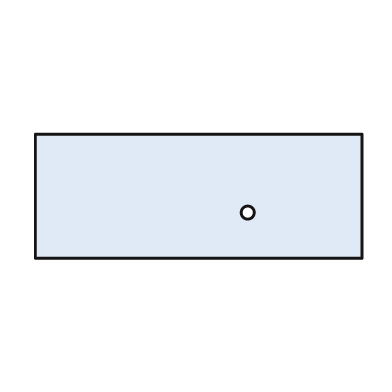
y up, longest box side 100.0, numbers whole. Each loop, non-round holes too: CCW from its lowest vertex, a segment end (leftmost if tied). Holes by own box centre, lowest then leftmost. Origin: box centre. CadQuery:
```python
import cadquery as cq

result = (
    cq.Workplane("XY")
    .moveTo(-50.0, -19.0)
    .lineTo(50.0, -19.0)
    .lineTo(50.0, 19.0)
    .lineTo(-50.0, 19.0)
    .close()
    .moveTo(15.0, -5.0)
    .circle(2.0)
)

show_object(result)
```